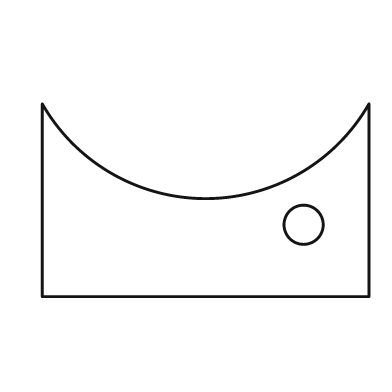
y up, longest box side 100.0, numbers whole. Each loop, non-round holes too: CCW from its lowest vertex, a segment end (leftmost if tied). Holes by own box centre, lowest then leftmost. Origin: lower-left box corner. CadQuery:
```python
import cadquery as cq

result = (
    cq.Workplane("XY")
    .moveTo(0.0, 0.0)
    .lineTo(100.0, 0.0)
    .lineTo(100.0, 59.0)
    .threePointArc((50.0, 30.0), (0.0, 59.0))
    .close()
    .moveTo(80.0, 22.0)
    .circle(6.0)
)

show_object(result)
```